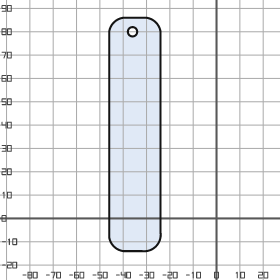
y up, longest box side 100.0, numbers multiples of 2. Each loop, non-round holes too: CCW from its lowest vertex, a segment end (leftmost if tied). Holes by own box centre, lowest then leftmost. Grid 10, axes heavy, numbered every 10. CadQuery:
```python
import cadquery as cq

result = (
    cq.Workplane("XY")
    .moveTo(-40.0, -14.0)
    .lineTo(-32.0, -14.0)
    .threePointArc((-26.0, -12.0), (-24.0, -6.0))
    .lineTo(-24.0, 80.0)
    .threePointArc((-26.0, 84.0), (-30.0, 86.0))
    .lineTo(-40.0, 86.0)
    .threePointArc((-44.0, 84.0), (-46.0, 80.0))
    .lineTo(-46.0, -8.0)
    .threePointArc((-44.0, -12.0), (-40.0, -14.0))
    .close()
    .moveTo(-36.0, 80.0)
    .circle(2.0)
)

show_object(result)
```